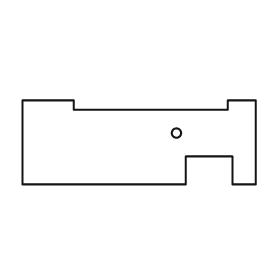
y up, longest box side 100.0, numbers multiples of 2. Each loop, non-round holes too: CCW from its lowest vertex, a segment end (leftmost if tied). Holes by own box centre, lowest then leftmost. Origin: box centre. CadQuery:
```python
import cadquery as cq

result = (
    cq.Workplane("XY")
    .moveTo(-50.0, -18.0)
    .lineTo(20.0, -18.0)
    .lineTo(20.0, -6.0)
    .lineTo(40.0, -6.0)
    .lineTo(40.0, -18.0)
    .lineTo(50.0, -18.0)
    .lineTo(50.0, 18.0)
    .lineTo(38.0, 18.0)
    .lineTo(38.0, 14.0)
    .lineTo(-28.0, 14.0)
    .lineTo(-28.0, 18.0)
    .lineTo(-50.0, 18.0)
    .close()
    .moveTo(16.0, 4.0)
    .circle(2.0)
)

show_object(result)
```